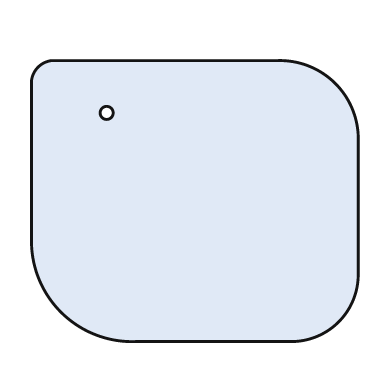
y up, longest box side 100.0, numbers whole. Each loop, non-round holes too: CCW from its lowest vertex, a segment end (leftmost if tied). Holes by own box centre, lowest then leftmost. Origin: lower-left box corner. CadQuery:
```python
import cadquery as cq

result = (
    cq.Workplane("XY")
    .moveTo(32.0, 0.0)
    .lineTo(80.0, 0.0)
    .threePointArc((94.0, 6.0), (100.0, 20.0))
    .lineTo(100.0, 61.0)
    .threePointArc((93.0, 79.0), (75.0, 86.0))
    .lineTo(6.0, 86.0)
    .threePointArc((2.0, 84.0), (0.0, 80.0))
    .lineTo(0.0, 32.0)
    .threePointArc((9.0, 9.0), (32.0, 0.0))
    .close()
    .moveTo(23.0, 70.0)
    .circle(2.0)
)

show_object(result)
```